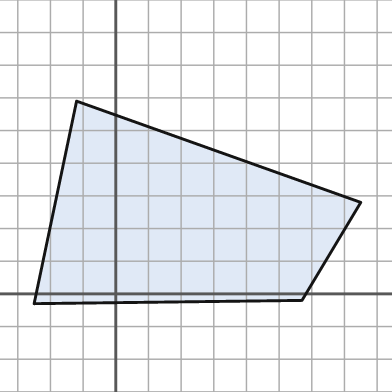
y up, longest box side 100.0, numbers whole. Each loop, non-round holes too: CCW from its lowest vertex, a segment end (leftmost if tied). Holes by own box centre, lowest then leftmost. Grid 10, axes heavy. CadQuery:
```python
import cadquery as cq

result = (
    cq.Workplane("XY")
    .moveTo(-25.0, -3.0)
    .lineTo(57.0, -2.0)
    .lineTo(75.0, 28.0)
    .lineTo(-12.0, 59.0)
    .close()
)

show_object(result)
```